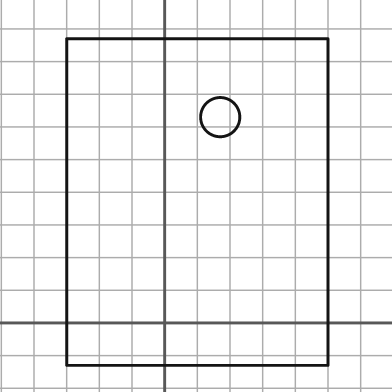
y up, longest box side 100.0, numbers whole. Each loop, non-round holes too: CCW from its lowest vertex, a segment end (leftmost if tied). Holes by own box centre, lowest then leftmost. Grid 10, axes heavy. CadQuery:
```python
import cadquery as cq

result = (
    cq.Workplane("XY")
    .moveTo(-30.0, -13.0)
    .lineTo(50.0, -13.0)
    .lineTo(50.0, 87.0)
    .lineTo(-30.0, 87.0)
    .close()
    .moveTo(17.0, 63.0)
    .circle(6.0)
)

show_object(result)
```